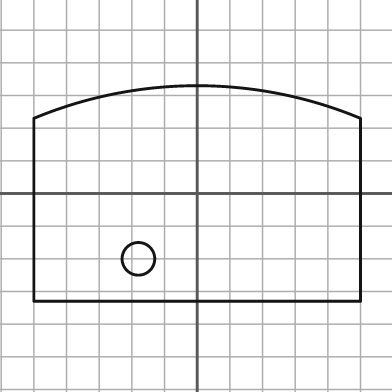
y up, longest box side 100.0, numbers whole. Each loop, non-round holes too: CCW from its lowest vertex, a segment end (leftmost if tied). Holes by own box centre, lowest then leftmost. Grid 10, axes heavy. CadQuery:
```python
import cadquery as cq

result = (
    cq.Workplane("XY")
    .moveTo(-50.0, -33.0)
    .lineTo(50.0, -33.0)
    .lineTo(50.0, 23.0)
    .threePointArc((0.0, 33.0), (-50.0, 23.0))
    .close()
    .moveTo(-18.0, -20.0)
    .circle(5.0)
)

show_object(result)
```